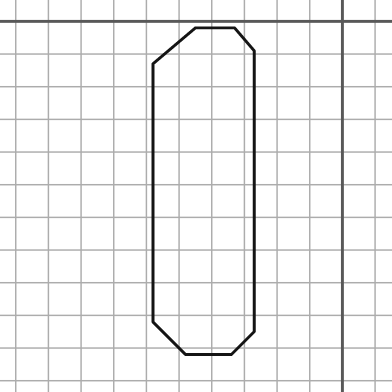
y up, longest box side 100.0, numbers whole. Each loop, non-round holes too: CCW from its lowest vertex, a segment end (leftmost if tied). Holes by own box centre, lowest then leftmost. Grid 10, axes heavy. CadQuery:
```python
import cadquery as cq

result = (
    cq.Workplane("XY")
    .moveTo(-48.0, -102.0)
    .lineTo(-34.0, -102.0)
    .lineTo(-27.0, -95.0)
    .lineTo(-27.0, -9.0)
    .lineTo(-33.0, -2.0)
    .lineTo(-45.0, -2.0)
    .lineTo(-58.0, -13.0)
    .lineTo(-58.0, -92.0)
    .close()
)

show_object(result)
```